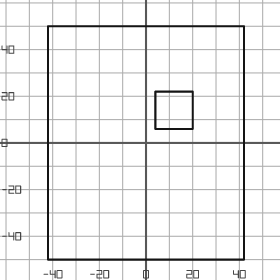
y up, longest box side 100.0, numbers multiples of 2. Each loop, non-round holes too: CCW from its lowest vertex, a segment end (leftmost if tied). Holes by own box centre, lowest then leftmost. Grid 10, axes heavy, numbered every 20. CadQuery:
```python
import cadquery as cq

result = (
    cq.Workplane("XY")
    .moveTo(-42.0, -50.0)
    .lineTo(42.0, -50.0)
    .lineTo(42.0, 50.0)
    .lineTo(-42.0, 50.0)
    .close()
    .moveTo(4.0, 6.0)
    .lineTo(20.0, 6.0)
    .lineTo(20.0, 22.0)
    .lineTo(4.0, 22.0)
    .close()
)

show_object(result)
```